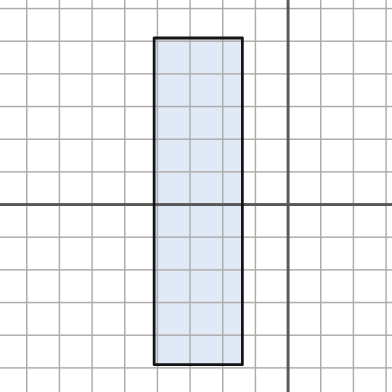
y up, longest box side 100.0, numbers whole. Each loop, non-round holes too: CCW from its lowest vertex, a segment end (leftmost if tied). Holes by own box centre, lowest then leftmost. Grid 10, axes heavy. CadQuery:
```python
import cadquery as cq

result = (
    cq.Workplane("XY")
    .moveTo(-41.0, -49.0)
    .lineTo(-14.0, -49.0)
    .lineTo(-14.0, 51.0)
    .lineTo(-41.0, 51.0)
    .close()
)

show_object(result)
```